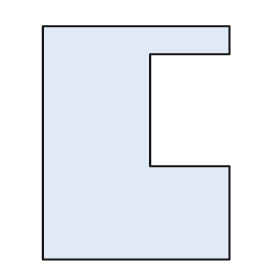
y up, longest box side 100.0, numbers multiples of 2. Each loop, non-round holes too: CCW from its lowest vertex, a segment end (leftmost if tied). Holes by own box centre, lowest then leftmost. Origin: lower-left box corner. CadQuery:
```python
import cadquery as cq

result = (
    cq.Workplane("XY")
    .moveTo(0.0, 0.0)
    .lineTo(80.0, 0.0)
    .lineTo(80.0, 40.0)
    .lineTo(46.0, 40.0)
    .lineTo(46.0, 88.0)
    .lineTo(80.0, 88.0)
    .lineTo(80.0, 100.0)
    .lineTo(0.0, 100.0)
    .close()
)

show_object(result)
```